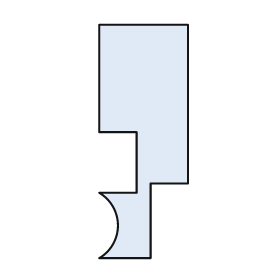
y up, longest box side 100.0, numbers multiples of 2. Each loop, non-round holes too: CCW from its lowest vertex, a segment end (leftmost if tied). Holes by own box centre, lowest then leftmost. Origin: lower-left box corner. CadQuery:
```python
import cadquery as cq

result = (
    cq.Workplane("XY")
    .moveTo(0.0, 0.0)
    .lineTo(22.0, 0.0)
    .lineTo(22.0, 32.0)
    .lineTo(38.0, 32.0)
    .lineTo(38.0, 100.0)
    .lineTo(0.0, 100.0)
    .lineTo(0.0, 54.0)
    .lineTo(16.0, 54.0)
    .lineTo(16.0, 28.0)
    .lineTo(0.0, 28.0)
    .threePointArc((8.0, 14.0), (0.0, 0.0))
    .close()
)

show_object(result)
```